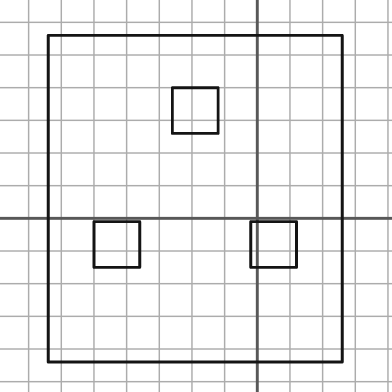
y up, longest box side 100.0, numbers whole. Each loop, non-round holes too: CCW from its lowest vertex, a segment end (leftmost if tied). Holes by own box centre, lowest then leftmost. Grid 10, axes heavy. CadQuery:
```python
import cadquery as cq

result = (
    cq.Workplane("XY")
    .moveTo(-64.0, -44.0)
    .lineTo(26.0, -44.0)
    .lineTo(26.0, 56.0)
    .lineTo(-64.0, 56.0)
    .close()
    .moveTo(-50.0, -15.0)
    .lineTo(-36.0, -15.0)
    .lineTo(-36.0, -1.0)
    .lineTo(-50.0, -1.0)
    .close()
    .moveTo(-2.0, -15.0)
    .lineTo(12.0, -15.0)
    .lineTo(12.0, -1.0)
    .lineTo(-2.0, -1.0)
    .close()
    .moveTo(-26.0, 26.0)
    .lineTo(-12.0, 26.0)
    .lineTo(-12.0, 40.0)
    .lineTo(-26.0, 40.0)
    .close()
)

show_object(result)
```